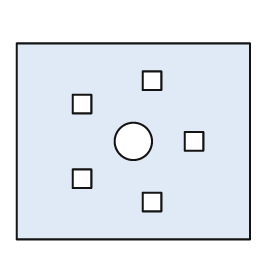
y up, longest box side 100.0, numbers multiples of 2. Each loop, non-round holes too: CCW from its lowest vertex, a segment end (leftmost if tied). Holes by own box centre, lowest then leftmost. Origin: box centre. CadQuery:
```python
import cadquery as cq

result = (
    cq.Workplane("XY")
    .moveTo(-50.0, -42.0)
    .lineTo(50.0, -42.0)
    .lineTo(50.0, 42.0)
    .lineTo(-50.0, 42.0)
    .close()
    .moveTo(4.0, -30.0)
    .lineTo(12.0, -30.0)
    .lineTo(12.0, -22.0)
    .lineTo(4.0, -22.0)
    .close()
    .moveTo(-26.0, -20.0)
    .lineTo(-18.0, -20.0)
    .lineTo(-18.0, -12.0)
    .lineTo(-26.0, -12.0)
    .close()
    .moveTo(0.0, 0.0)
    .circle(8.0)
    .moveTo(22.0, -4.0)
    .lineTo(30.0, -4.0)
    .lineTo(30.0, 4.0)
    .lineTo(22.0, 4.0)
    .close()
    .moveTo(-26.0, 12.0)
    .lineTo(-18.0, 12.0)
    .lineTo(-18.0, 20.0)
    .lineTo(-26.0, 20.0)
    .close()
    .moveTo(4.0, 22.0)
    .lineTo(12.0, 22.0)
    .lineTo(12.0, 30.0)
    .lineTo(4.0, 30.0)
    .close()
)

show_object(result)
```